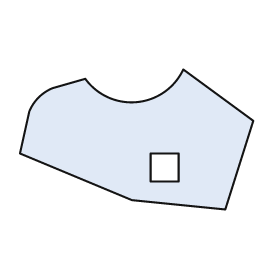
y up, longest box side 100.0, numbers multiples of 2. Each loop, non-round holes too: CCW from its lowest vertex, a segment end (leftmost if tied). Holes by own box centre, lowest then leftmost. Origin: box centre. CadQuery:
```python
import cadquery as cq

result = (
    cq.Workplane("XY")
    .moveTo(38.0, -30.0)
    .lineTo(50.0, 8.0)
    .lineTo(20.0, 30.0)
    .threePointArc((0.0, 16.0), (-22.0, 26.0))
    .lineTo(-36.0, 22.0)
    .threePointArc((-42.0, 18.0), (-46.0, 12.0))
    .lineTo(-50.0, -6.0)
    .lineTo(-2.0, -26.0)
    .close()
    .moveTo(6.0, -18.0)
    .lineTo(18.0, -18.0)
    .lineTo(18.0, -6.0)
    .lineTo(6.0, -6.0)
    .close()
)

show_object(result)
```